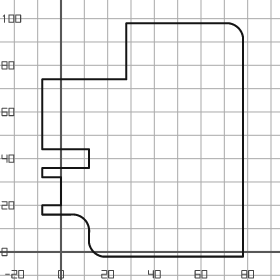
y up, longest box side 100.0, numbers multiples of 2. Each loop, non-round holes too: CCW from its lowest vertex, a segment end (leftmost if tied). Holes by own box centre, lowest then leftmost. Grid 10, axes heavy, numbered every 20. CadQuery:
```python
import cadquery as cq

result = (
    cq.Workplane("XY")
    .moveTo(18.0, -2.0)
    .lineTo(78.0, -2.0)
    .lineTo(78.0, 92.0)
    .threePointArc((76.0, 96.0), (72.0, 98.0))
    .lineTo(28.0, 98.0)
    .lineTo(28.0, 74.0)
    .lineTo(-8.0, 74.0)
    .lineTo(-8.0, 44.0)
    .lineTo(12.0, 44.0)
    .lineTo(12.0, 36.0)
    .lineTo(-8.0, 36.0)
    .lineTo(-8.0, 32.0)
    .lineTo(0.0, 32.0)
    .lineTo(0.0, 20.0)
    .lineTo(-8.0, 20.0)
    .lineTo(-8.0, 16.0)
    .lineTo(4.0, 16.0)
    .threePointArc((10.0, 14.0), (12.0, 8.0))
    .lineTo(12.0, 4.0)
    .threePointArc((14.0, 0.0), (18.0, -2.0))
    .close()
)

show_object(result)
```